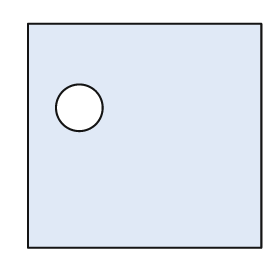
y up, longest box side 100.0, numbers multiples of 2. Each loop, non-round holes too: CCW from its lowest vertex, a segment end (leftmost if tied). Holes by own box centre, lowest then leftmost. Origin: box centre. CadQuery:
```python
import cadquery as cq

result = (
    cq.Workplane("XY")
    .moveTo(-50.0, -48.0)
    .lineTo(50.0, -48.0)
    .lineTo(50.0, 48.0)
    .lineTo(-50.0, 48.0)
    .close()
    .moveTo(-28.0, 12.0)
    .circle(10.0)
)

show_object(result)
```